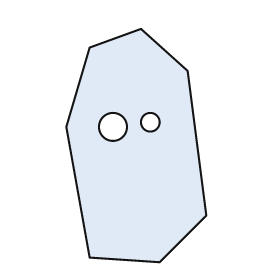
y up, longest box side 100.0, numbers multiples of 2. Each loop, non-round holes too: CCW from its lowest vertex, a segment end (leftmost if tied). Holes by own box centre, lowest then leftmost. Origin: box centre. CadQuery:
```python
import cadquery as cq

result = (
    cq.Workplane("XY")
    .moveTo(10.0, -50.0)
    .lineTo(30.0, -30.0)
    .lineTo(22.0, 32.0)
    .lineTo(2.0, 50.0)
    .lineTo(-20.0, 42.0)
    .lineTo(-30.0, 8.0)
    .lineTo(-20.0, -48.0)
    .close()
    .moveTo(-10.0, 8.0)
    .circle(6.0)
    .moveTo(6.0, 10.0)
    .circle(4.0)
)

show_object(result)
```